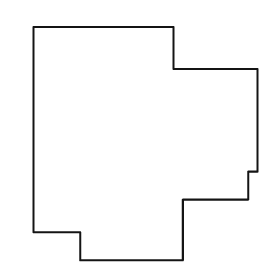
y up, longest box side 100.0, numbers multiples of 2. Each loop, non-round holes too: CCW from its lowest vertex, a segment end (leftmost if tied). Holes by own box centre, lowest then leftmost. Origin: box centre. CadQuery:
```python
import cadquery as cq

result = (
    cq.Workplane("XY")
    .moveTo(-28.0, -50.0)
    .lineTo(16.0, -50.0)
    .lineTo(16.0, -24.0)
    .lineTo(44.0, -24.0)
    .lineTo(44.0, -12.0)
    .lineTo(48.0, -12.0)
    .lineTo(48.0, 32.0)
    .lineTo(12.0, 32.0)
    .lineTo(12.0, 50.0)
    .lineTo(-48.0, 50.0)
    .lineTo(-48.0, -38.0)
    .lineTo(-28.0, -38.0)
    .close()
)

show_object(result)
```